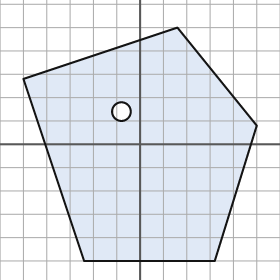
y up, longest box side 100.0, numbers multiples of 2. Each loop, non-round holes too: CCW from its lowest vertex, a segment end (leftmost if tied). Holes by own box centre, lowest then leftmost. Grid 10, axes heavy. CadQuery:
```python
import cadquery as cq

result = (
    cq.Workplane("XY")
    .moveTo(-24.0, -50.0)
    .lineTo(32.0, -50.0)
    .lineTo(50.0, 8.0)
    .lineTo(16.0, 50.0)
    .lineTo(-50.0, 28.0)
    .close()
    .moveTo(-8.0, 14.0)
    .circle(4.0)
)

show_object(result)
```